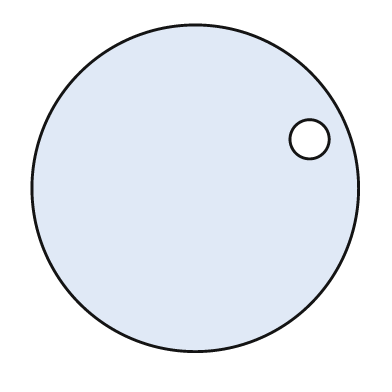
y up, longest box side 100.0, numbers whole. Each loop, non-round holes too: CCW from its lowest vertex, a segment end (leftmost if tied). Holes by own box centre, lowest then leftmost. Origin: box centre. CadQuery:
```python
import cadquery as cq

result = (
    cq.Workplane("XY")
    .moveTo(0.0, 0.0)
    .circle(50.0)
    .moveTo(35.0, 15.0)
    .circle(6.0)
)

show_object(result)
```